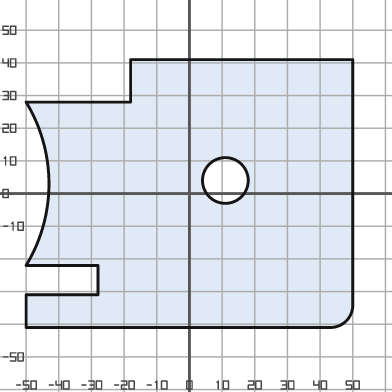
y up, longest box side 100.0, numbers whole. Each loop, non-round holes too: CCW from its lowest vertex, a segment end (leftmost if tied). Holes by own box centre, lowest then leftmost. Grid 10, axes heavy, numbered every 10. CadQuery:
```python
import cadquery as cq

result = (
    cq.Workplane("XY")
    .moveTo(-50.0, -41.0)
    .lineTo(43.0, -41.0)
    .threePointArc((48.0, -39.0), (50.0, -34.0))
    .lineTo(50.0, 41.0)
    .lineTo(-18.0, 41.0)
    .lineTo(-18.0, 28.0)
    .lineTo(-50.0, 28.0)
    .threePointArc((-43.0, 3.0), (-50.0, -22.0))
    .lineTo(-28.0, -22.0)
    .lineTo(-28.0, -31.0)
    .lineTo(-50.0, -31.0)
    .close()
    .moveTo(11.0, 4.0)
    .circle(7.0)
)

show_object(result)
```